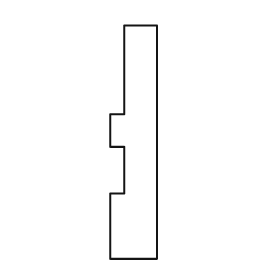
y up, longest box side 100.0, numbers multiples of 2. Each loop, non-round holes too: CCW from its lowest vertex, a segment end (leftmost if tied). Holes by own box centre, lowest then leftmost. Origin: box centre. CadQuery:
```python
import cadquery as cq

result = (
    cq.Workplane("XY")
    .moveTo(-10.0, -50.0)
    .lineTo(10.0, -50.0)
    .lineTo(10.0, 50.0)
    .lineTo(-4.0, 50.0)
    .lineTo(-4.0, 12.0)
    .lineTo(-10.0, 12.0)
    .lineTo(-10.0, -2.0)
    .lineTo(-4.0, -2.0)
    .lineTo(-4.0, -22.0)
    .lineTo(-10.0, -22.0)
    .close()
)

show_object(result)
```